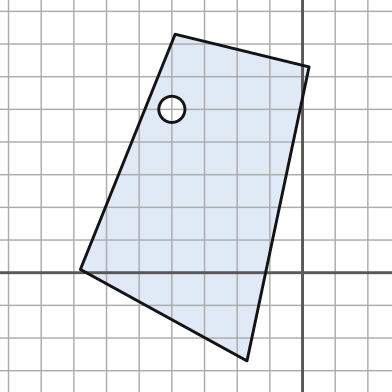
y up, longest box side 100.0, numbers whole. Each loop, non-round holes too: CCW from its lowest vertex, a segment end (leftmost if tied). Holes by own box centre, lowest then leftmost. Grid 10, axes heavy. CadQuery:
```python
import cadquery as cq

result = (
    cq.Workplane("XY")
    .moveTo(-17.0, -27.0)
    .lineTo(2.0, 63.0)
    .lineTo(-39.0, 73.0)
    .lineTo(-68.0, 1.0)
    .close()
    .moveTo(-40.0, 50.0)
    .circle(4.0)
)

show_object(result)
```